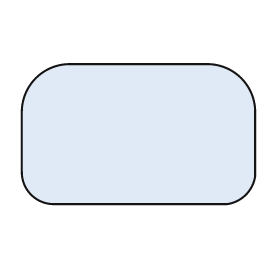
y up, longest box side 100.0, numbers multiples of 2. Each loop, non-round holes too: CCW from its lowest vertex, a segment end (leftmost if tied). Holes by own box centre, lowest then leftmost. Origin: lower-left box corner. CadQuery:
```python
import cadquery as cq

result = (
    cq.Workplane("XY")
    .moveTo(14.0, 0.0)
    .lineTo(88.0, 0.0)
    .threePointArc((96.0, 4.0), (100.0, 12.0))
    .lineTo(100.0, 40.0)
    .threePointArc((94.0, 54.0), (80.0, 60.0))
    .lineTo(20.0, 60.0)
    .threePointArc((6.0, 54.0), (0.0, 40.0))
    .lineTo(0.0, 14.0)
    .threePointArc((4.0, 4.0), (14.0, 0.0))
    .close()
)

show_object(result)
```